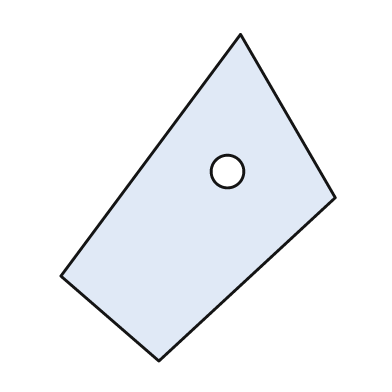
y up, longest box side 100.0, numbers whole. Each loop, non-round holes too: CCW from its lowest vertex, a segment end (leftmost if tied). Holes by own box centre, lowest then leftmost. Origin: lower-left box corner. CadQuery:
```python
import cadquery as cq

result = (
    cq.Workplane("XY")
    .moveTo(30.0, 0.0)
    .lineTo(84.0, 50.0)
    .lineTo(55.0, 100.0)
    .lineTo(0.0, 26.0)
    .close()
    .moveTo(51.0, 58.0)
    .circle(5.0)
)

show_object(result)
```